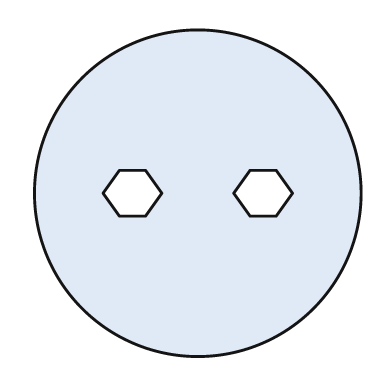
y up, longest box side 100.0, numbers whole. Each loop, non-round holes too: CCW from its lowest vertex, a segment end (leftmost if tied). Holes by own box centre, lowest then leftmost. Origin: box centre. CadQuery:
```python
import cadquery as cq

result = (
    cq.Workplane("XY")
    .moveTo(0.0, 0.0)
    .circle(50.0)
    .moveTo(-24.0, -7.0)
    .lineTo(-16.0, -7.0)
    .lineTo(-11.0, 0.0)
    .lineTo(-16.0, 7.0)
    .lineTo(-24.0, 7.0)
    .lineTo(-29.0, 0.0)
    .close()
    .moveTo(16.0, -7.0)
    .lineTo(24.0, -7.0)
    .lineTo(29.0, 0.0)
    .lineTo(24.0, 7.0)
    .lineTo(16.0, 7.0)
    .lineTo(11.0, 0.0)
    .close()
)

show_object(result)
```